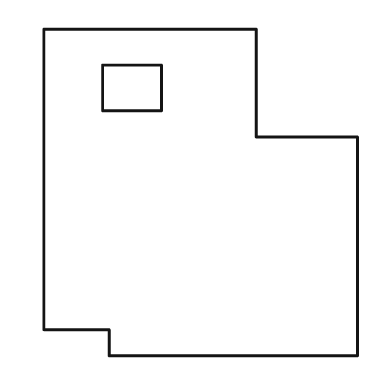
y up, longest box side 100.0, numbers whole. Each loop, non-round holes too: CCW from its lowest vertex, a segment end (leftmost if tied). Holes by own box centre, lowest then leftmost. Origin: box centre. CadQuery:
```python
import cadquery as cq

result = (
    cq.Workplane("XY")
    .moveTo(-28.0, -50.0)
    .lineTo(48.0, -50.0)
    .lineTo(48.0, 17.0)
    .lineTo(17.0, 17.0)
    .lineTo(17.0, 50.0)
    .lineTo(-48.0, 50.0)
    .lineTo(-48.0, -42.0)
    .lineTo(-28.0, -42.0)
    .close()
    .moveTo(-30.0, 25.0)
    .lineTo(-12.0, 25.0)
    .lineTo(-12.0, 39.0)
    .lineTo(-30.0, 39.0)
    .close()
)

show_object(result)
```